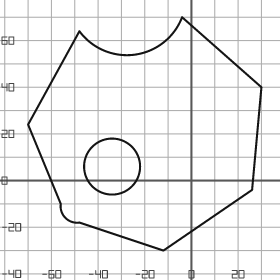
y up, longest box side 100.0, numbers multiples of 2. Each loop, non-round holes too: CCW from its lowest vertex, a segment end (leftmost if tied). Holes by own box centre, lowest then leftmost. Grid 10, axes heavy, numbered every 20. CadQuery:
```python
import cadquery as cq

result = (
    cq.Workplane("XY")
    .moveTo(-12.0, -30.0)
    .lineTo(26.0, -4.0)
    .lineTo(30.0, 40.0)
    .lineTo(-4.0, 70.0)
    .threePointArc((-24.0, 54.0), (-48.0, 64.0))
    .lineTo(-70.0, 24.0)
    .lineTo(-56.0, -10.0)
    .threePointArc((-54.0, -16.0), (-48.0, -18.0))
    .close()
    .moveTo(-34.0, 6.0)
    .circle(12.0)
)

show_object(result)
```